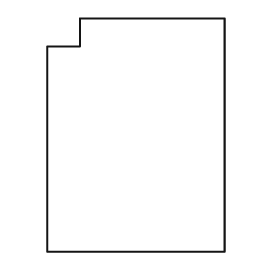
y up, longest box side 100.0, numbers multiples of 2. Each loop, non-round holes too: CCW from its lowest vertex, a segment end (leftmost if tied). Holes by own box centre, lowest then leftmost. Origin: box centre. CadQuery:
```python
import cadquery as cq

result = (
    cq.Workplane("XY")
    .moveTo(-38.0, -50.0)
    .lineTo(38.0, -50.0)
    .lineTo(38.0, 50.0)
    .lineTo(-24.0, 50.0)
    .lineTo(-24.0, 38.0)
    .lineTo(-38.0, 38.0)
    .close()
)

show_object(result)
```